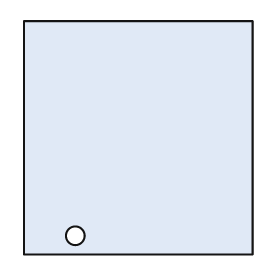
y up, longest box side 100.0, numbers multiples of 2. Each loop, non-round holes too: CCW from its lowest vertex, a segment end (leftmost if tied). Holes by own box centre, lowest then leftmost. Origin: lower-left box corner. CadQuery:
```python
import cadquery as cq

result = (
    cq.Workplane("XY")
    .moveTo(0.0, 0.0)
    .lineTo(98.0, 0.0)
    .lineTo(98.0, 100.0)
    .lineTo(0.0, 100.0)
    .close()
    .moveTo(22.0, 8.0)
    .circle(4.0)
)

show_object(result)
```